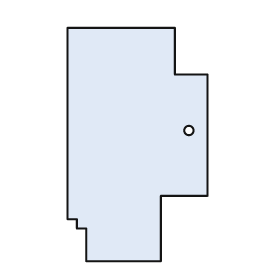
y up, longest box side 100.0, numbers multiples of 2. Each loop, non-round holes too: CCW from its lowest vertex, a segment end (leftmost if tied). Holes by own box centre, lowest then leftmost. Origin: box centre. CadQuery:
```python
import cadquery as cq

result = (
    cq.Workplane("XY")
    .moveTo(-22.0, -50.0)
    .lineTo(10.0, -50.0)
    .lineTo(10.0, -22.0)
    .lineTo(30.0, -22.0)
    .lineTo(30.0, 30.0)
    .lineTo(16.0, 30.0)
    .lineTo(16.0, 50.0)
    .lineTo(-30.0, 50.0)
    .lineTo(-30.0, -32.0)
    .lineTo(-26.0, -32.0)
    .lineTo(-26.0, -36.0)
    .lineTo(-22.0, -36.0)
    .close()
    .moveTo(22.0, 6.0)
    .circle(2.0)
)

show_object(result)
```